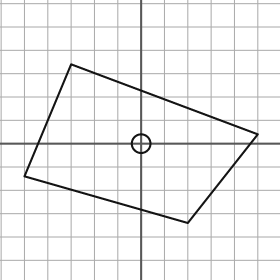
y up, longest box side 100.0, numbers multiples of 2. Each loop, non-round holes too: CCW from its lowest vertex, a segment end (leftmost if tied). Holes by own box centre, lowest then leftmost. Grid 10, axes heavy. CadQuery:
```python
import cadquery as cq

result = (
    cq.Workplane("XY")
    .moveTo(20.0, -34.0)
    .lineTo(50.0, 4.0)
    .lineTo(-30.0, 34.0)
    .lineTo(-50.0, -14.0)
    .close()
    .moveTo(0.0, 0.0)
    .circle(4.0)
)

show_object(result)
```